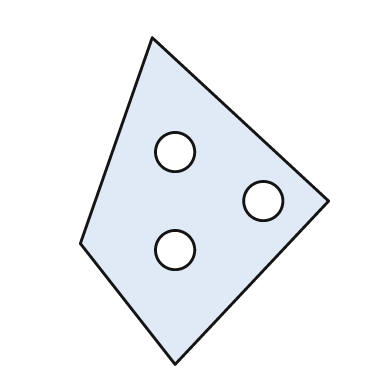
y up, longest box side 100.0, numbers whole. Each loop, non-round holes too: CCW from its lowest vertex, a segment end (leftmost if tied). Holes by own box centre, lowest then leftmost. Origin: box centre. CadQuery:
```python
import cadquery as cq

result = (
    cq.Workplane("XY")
    .moveTo(-9.0, -50.0)
    .lineTo(38.0, 0.0)
    .lineTo(-16.0, 50.0)
    .lineTo(-38.0, -13.0)
    .close()
    .moveTo(-9.0, -15.0)
    .circle(6.0)
    .moveTo(18.0, 0.0)
    .circle(6.0)
    .moveTo(-9.0, 15.0)
    .circle(6.0)
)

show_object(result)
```